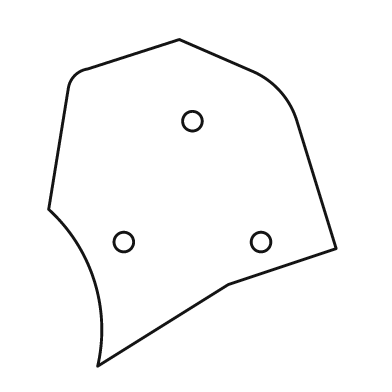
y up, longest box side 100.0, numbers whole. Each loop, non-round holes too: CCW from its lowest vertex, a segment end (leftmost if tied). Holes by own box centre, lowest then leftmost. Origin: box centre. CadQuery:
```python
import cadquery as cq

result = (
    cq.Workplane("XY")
    .moveTo(-29.0, -50.0)
    .lineTo(11.0, -25.0)
    .lineTo(44.0, -14.0)
    .lineTo(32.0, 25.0)
    .threePointArc((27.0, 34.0), (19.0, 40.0))
    .lineTo(-4.0, 50.0)
    .lineTo(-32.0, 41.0)
    .threePointArc((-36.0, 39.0), (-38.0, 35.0))
    .lineTo(-44.0, -2.0)
    .threePointArc((-30.0, -24.0), (-29.0, -50.0))
    .close()
    .moveTo(-21.0, -12.0)
    .circle(3.0)
    .moveTo(21.0, -12.0)
    .circle(3.0)
    .moveTo(0.0, 25.0)
    .circle(3.0)
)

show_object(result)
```